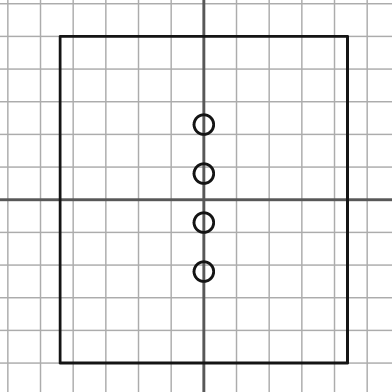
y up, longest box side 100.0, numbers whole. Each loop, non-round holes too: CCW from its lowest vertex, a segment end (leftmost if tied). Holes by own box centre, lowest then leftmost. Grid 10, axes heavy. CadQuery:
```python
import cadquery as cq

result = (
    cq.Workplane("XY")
    .moveTo(-44.0, -50.0)
    .lineTo(44.0, -50.0)
    .lineTo(44.0, 50.0)
    .lineTo(-44.0, 50.0)
    .close()
    .moveTo(0.0, -22.0)
    .circle(3.0)
    .moveTo(0.0, -7.0)
    .circle(3.0)
    .moveTo(0.0, 8.0)
    .circle(3.0)
    .moveTo(0.0, 23.0)
    .circle(3.0)
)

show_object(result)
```